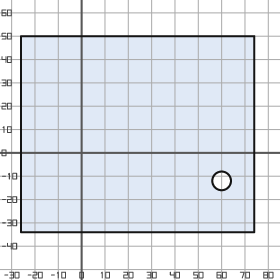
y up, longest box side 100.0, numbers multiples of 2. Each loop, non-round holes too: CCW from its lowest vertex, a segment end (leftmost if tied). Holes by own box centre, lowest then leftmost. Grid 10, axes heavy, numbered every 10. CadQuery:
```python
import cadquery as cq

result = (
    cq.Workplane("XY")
    .moveTo(-26.0, -34.0)
    .lineTo(74.0, -34.0)
    .lineTo(74.0, 50.0)
    .lineTo(-26.0, 50.0)
    .close()
    .moveTo(60.0, -12.0)
    .circle(4.0)
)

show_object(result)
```